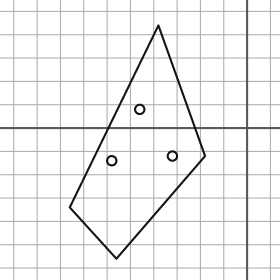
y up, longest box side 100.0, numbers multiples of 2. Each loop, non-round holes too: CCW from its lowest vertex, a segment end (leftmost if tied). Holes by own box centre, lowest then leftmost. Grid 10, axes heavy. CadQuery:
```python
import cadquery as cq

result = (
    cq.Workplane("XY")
    .moveTo(-56.0, -56.0)
    .lineTo(-18.0, -12.0)
    .lineTo(-38.0, 44.0)
    .lineTo(-76.0, -34.0)
    .close()
    .moveTo(-58.0, -14.0)
    .circle(2.0)
    .moveTo(-32.0, -12.0)
    .circle(2.0)
    .moveTo(-46.0, 8.0)
    .circle(2.0)
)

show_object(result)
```